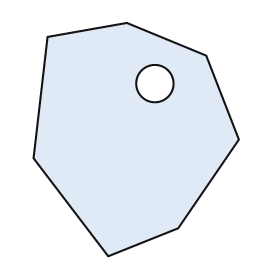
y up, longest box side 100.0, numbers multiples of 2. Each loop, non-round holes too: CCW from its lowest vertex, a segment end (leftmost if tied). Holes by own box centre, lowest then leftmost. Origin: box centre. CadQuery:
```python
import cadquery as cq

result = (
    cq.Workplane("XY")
    .moveTo(-12.0, -50.0)
    .lineTo(18.0, -38.0)
    .lineTo(44.0, 0.0)
    .lineTo(30.0, 36.0)
    .lineTo(-4.0, 50.0)
    .lineTo(-38.0, 44.0)
    .lineTo(-44.0, -8.0)
    .close()
    .moveTo(8.0, 24.0)
    .circle(8.0)
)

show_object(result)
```